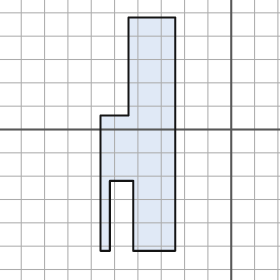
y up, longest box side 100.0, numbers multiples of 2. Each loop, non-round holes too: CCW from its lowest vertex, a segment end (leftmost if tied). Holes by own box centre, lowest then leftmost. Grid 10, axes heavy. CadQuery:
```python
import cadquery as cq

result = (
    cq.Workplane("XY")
    .moveTo(-56.0, -52.0)
    .lineTo(-52.0, -52.0)
    .lineTo(-52.0, -22.0)
    .lineTo(-42.0, -22.0)
    .lineTo(-42.0, -52.0)
    .lineTo(-24.0, -52.0)
    .lineTo(-24.0, 48.0)
    .lineTo(-44.0, 48.0)
    .lineTo(-44.0, 6.0)
    .lineTo(-56.0, 6.0)
    .close()
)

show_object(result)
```